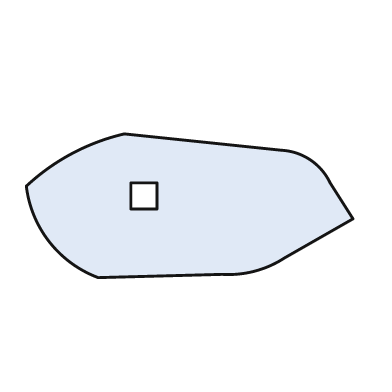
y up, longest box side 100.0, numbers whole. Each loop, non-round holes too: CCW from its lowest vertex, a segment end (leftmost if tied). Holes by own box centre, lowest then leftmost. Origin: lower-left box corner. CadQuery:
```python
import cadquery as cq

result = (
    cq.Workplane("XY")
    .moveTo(22.0, 0.0)
    .lineTo(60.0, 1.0)
    .threePointArc((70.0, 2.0), (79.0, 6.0))
    .lineTo(100.0, 18.0)
    .lineTo(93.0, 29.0)
    .threePointArc((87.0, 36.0), (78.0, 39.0))
    .lineTo(30.0, 44.0)
    .threePointArc((14.0, 38.0), (0.0, 28.0))
    .threePointArc((7.0, 11.0), (22.0, 0.0))
    .close()
    .moveTo(32.0, 21.0)
    .lineTo(40.0, 21.0)
    .lineTo(40.0, 29.0)
    .lineTo(32.0, 29.0)
    .close()
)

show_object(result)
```